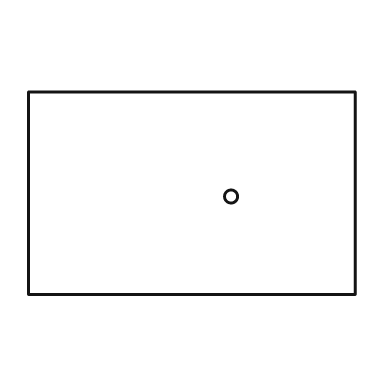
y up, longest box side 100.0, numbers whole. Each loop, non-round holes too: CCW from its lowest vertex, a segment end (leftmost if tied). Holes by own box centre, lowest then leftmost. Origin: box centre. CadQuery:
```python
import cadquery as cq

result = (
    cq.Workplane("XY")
    .moveTo(-50.0, -31.0)
    .lineTo(50.0, -31.0)
    .lineTo(50.0, 31.0)
    .lineTo(-50.0, 31.0)
    .close()
    .moveTo(12.0, -1.0)
    .circle(2.0)
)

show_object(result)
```